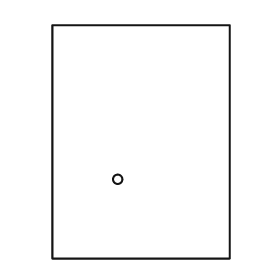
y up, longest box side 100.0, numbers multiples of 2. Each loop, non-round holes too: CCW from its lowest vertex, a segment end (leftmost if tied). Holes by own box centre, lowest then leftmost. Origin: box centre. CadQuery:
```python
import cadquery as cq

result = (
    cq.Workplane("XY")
    .moveTo(-38.0, -50.0)
    .lineTo(38.0, -50.0)
    .lineTo(38.0, 50.0)
    .lineTo(-38.0, 50.0)
    .close()
    .moveTo(-10.0, -16.0)
    .circle(2.0)
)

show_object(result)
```